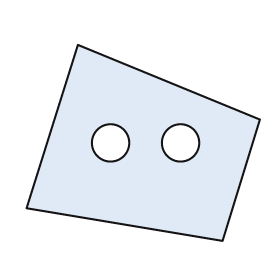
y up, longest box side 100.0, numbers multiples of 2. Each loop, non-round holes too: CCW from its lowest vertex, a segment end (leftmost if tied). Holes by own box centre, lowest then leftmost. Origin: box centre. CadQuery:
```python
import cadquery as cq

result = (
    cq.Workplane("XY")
    .moveTo(34.0, -42.0)
    .lineTo(50.0, 10.0)
    .lineTo(-28.0, 42.0)
    .lineTo(-50.0, -28.0)
    .close()
    .moveTo(-14.0, 0.0)
    .circle(8.0)
    .moveTo(16.0, 0.0)
    .circle(8.0)
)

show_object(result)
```